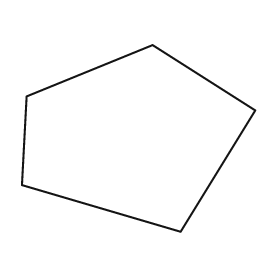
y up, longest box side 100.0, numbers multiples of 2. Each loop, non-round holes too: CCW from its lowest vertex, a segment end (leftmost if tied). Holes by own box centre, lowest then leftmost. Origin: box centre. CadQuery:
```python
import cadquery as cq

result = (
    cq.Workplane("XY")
    .moveTo(18.0, -40.0)
    .lineTo(50.0, 12.0)
    .lineTo(6.0, 40.0)
    .lineTo(-48.0, 18.0)
    .lineTo(-50.0, -20.0)
    .close()
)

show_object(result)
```